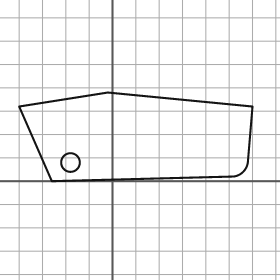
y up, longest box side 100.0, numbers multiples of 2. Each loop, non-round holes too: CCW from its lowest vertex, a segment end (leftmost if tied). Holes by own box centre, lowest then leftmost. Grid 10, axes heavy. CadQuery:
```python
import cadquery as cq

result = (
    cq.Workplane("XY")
    .moveTo(-26.0, 0.0)
    .lineTo(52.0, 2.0)
    .threePointArc((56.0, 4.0), (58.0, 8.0))
    .lineTo(60.0, 32.0)
    .lineTo(-2.0, 38.0)
    .lineTo(-40.0, 32.0)
    .close()
    .moveTo(-18.0, 8.0)
    .circle(4.0)
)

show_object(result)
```